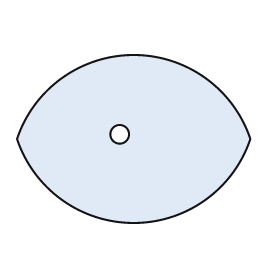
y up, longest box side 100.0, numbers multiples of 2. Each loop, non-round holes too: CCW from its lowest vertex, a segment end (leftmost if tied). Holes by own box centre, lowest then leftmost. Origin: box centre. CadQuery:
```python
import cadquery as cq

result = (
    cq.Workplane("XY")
    .moveTo(-50.0, 0.0)
    .threePointArc((0.0, -36.0), (50.0, 0.0))
    .threePointArc((0.0, 36.0), (-50.0, 0.0))
    .close()
    .moveTo(-6.0, 2.0)
    .circle(4.0)
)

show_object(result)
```